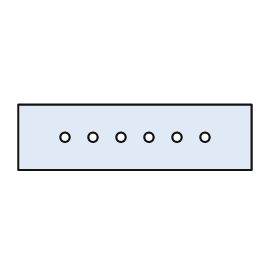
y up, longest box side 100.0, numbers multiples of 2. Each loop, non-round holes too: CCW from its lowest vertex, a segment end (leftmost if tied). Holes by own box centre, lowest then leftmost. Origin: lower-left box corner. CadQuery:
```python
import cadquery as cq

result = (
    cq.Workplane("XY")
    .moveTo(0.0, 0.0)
    .lineTo(100.0, 0.0)
    .lineTo(100.0, 28.0)
    .lineTo(0.0, 28.0)
    .close()
    .moveTo(20.0, 14.0)
    .circle(2.0)
    .moveTo(32.0, 14.0)
    .circle(2.0)
    .moveTo(44.0, 14.0)
    .circle(2.0)
    .moveTo(56.0, 14.0)
    .circle(2.0)
    .moveTo(68.0, 14.0)
    .circle(2.0)
    .moveTo(80.0, 14.0)
    .circle(2.0)
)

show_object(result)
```